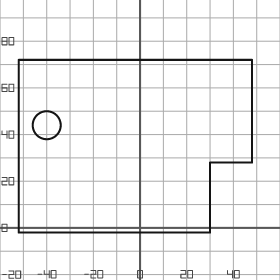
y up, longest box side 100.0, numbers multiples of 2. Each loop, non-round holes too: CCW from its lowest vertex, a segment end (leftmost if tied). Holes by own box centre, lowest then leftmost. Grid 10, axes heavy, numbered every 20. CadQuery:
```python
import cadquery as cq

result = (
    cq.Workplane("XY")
    .moveTo(-52.0, -2.0)
    .lineTo(30.0, -2.0)
    .lineTo(30.0, 28.0)
    .lineTo(48.0, 28.0)
    .lineTo(48.0, 72.0)
    .lineTo(-52.0, 72.0)
    .close()
    .moveTo(-40.0, 44.0)
    .circle(6.0)
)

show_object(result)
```